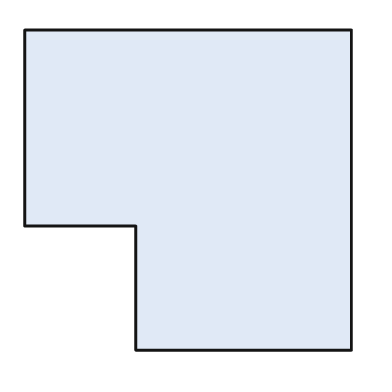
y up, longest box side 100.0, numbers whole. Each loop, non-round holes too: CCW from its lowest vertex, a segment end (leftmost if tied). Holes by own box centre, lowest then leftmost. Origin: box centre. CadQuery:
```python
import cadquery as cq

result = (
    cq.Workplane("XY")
    .moveTo(-16.0, -49.0)
    .lineTo(50.0, -49.0)
    .lineTo(50.0, 49.0)
    .lineTo(-50.0, 49.0)
    .lineTo(-50.0, -11.0)
    .lineTo(-16.0, -11.0)
    .close()
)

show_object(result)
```